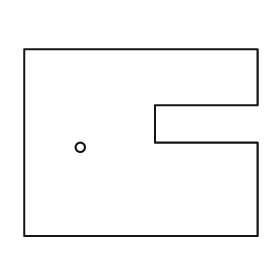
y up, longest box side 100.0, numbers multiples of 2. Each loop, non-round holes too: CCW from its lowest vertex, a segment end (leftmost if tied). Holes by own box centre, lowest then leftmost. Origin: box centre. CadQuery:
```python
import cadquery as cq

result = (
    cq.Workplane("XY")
    .moveTo(-50.0, -40.0)
    .lineTo(50.0, -40.0)
    .lineTo(50.0, 0.0)
    .lineTo(6.0, 0.0)
    .lineTo(6.0, 16.0)
    .lineTo(50.0, 16.0)
    .lineTo(50.0, 40.0)
    .lineTo(-50.0, 40.0)
    .close()
    .moveTo(-26.0, -2.0)
    .circle(2.0)
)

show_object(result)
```